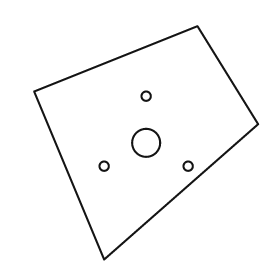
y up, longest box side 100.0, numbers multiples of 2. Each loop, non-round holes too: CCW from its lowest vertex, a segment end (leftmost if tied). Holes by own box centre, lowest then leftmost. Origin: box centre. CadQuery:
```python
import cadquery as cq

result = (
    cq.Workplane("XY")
    .moveTo(-18.0, -50.0)
    .lineTo(48.0, 8.0)
    .lineTo(22.0, 50.0)
    .lineTo(-48.0, 22.0)
    .close()
    .moveTo(-18.0, -10.0)
    .circle(2.0)
    .moveTo(18.0, -10.0)
    .circle(2.0)
    .moveTo(0.0, 0.0)
    .circle(6.0)
    .moveTo(0.0, 20.0)
    .circle(2.0)
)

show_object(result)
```